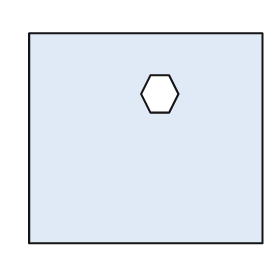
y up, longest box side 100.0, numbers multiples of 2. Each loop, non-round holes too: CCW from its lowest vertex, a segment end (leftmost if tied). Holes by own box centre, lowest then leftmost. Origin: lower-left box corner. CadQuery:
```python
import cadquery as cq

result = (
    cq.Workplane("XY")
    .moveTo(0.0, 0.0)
    .lineTo(100.0, 0.0)
    .lineTo(100.0, 90.0)
    .lineTo(0.0, 90.0)
    .close()
    .moveTo(52.0, 56.0)
    .lineTo(60.0, 56.0)
    .lineTo(64.0, 64.0)
    .lineTo(60.0, 72.0)
    .lineTo(52.0, 72.0)
    .lineTo(48.0, 64.0)
    .close()
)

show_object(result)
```